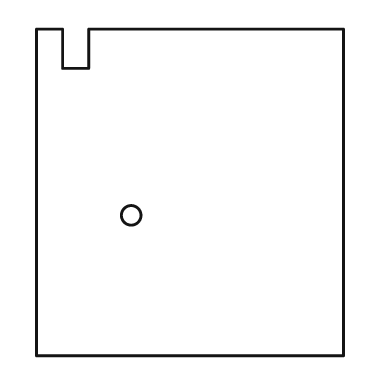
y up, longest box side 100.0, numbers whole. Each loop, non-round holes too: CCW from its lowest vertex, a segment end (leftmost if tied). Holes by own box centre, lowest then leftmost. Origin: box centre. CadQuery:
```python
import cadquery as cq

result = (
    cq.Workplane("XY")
    .moveTo(-47.0, -50.0)
    .lineTo(47.0, -50.0)
    .lineTo(47.0, 50.0)
    .lineTo(-31.0, 50.0)
    .lineTo(-31.0, 38.0)
    .lineTo(-39.0, 38.0)
    .lineTo(-39.0, 50.0)
    .lineTo(-47.0, 50.0)
    .close()
    .moveTo(-18.0, -7.0)
    .circle(3.0)
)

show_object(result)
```